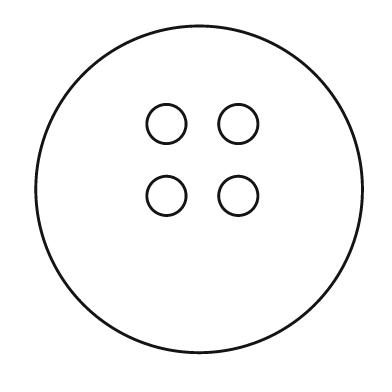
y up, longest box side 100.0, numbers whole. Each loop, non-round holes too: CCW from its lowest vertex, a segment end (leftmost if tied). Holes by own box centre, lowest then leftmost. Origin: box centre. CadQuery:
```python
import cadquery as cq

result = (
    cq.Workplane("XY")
    .moveTo(0.0, 0.0)
    .circle(50.0)
    .moveTo(-10.0, -2.0)
    .circle(6.0)
    .moveTo(12.0, -2.0)
    .circle(6.0)
    .moveTo(-10.0, 20.0)
    .circle(6.0)
    .moveTo(12.0, 20.0)
    .circle(6.0)
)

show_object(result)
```